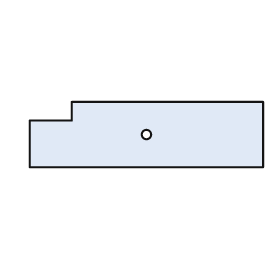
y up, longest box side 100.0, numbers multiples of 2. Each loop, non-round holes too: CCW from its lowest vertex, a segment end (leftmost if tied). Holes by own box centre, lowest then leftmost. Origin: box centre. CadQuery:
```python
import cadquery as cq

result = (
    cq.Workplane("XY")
    .moveTo(-50.0, -14.0)
    .lineTo(50.0, -14.0)
    .lineTo(50.0, 14.0)
    .lineTo(-32.0, 14.0)
    .lineTo(-32.0, 6.0)
    .lineTo(-50.0, 6.0)
    .close()
    .moveTo(0.0, 0.0)
    .circle(2.0)
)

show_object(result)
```